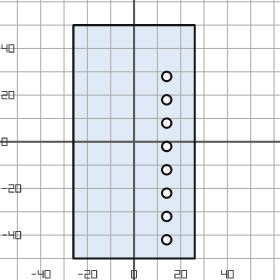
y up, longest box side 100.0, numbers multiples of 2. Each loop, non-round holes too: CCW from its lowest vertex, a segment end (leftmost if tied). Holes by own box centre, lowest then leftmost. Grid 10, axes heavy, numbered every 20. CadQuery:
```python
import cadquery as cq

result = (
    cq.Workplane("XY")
    .moveTo(-26.0, -50.0)
    .lineTo(26.0, -50.0)
    .lineTo(26.0, 50.0)
    .lineTo(-26.0, 50.0)
    .close()
    .moveTo(14.0, -42.0)
    .circle(2.0)
    .moveTo(14.0, -32.0)
    .circle(2.0)
    .moveTo(14.0, -22.0)
    .circle(2.0)
    .moveTo(14.0, -12.0)
    .circle(2.0)
    .moveTo(14.0, -2.0)
    .circle(2.0)
    .moveTo(14.0, 8.0)
    .circle(2.0)
    .moveTo(14.0, 18.0)
    .circle(2.0)
    .moveTo(14.0, 28.0)
    .circle(2.0)
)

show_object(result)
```